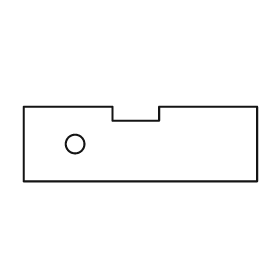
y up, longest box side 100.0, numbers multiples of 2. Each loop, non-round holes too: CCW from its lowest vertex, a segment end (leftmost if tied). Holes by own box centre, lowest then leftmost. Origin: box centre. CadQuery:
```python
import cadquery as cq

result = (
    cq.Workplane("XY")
    .moveTo(-50.0, -16.0)
    .lineTo(50.0, -16.0)
    .lineTo(50.0, 16.0)
    .lineTo(8.0, 16.0)
    .lineTo(8.0, 10.0)
    .lineTo(-12.0, 10.0)
    .lineTo(-12.0, 16.0)
    .lineTo(-50.0, 16.0)
    .close()
    .moveTo(-28.0, 0.0)
    .circle(4.0)
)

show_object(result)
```